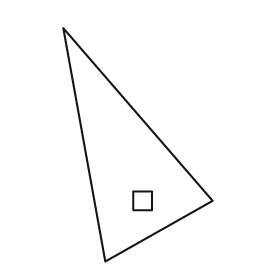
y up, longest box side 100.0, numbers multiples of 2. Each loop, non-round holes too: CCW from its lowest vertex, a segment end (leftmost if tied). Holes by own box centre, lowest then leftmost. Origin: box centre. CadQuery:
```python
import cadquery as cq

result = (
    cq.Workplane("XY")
    .moveTo(-14.0, -50.0)
    .lineTo(32.0, -24.0)
    .lineTo(-32.0, 50.0)
    .close()
    .moveTo(-2.0, -28.0)
    .lineTo(6.0, -28.0)
    .lineTo(6.0, -20.0)
    .lineTo(-2.0, -20.0)
    .close()
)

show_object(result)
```